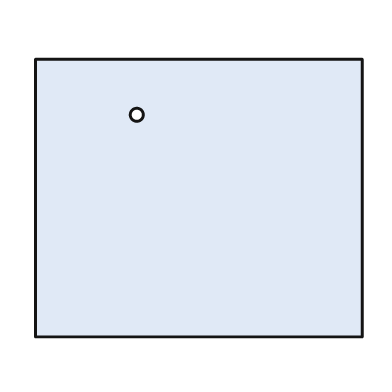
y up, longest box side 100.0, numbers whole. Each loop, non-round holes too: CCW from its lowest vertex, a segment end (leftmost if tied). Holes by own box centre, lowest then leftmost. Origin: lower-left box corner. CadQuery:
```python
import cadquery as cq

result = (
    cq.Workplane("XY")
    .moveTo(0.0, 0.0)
    .lineTo(100.0, 0.0)
    .lineTo(100.0, 85.0)
    .lineTo(0.0, 85.0)
    .close()
    .moveTo(31.0, 68.0)
    .circle(2.0)
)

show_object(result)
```